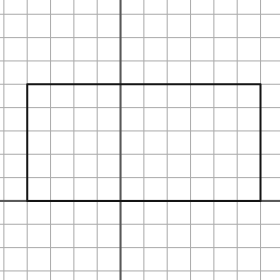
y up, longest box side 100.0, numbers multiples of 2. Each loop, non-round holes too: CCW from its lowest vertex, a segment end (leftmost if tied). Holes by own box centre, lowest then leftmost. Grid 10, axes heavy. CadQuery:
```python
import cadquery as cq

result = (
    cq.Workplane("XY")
    .moveTo(-40.0, 0.0)
    .lineTo(60.0, 0.0)
    .lineTo(60.0, 50.0)
    .lineTo(-40.0, 50.0)
    .close()
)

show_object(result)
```